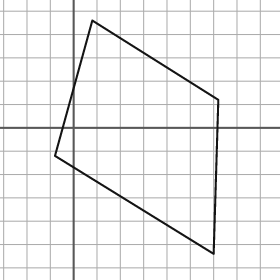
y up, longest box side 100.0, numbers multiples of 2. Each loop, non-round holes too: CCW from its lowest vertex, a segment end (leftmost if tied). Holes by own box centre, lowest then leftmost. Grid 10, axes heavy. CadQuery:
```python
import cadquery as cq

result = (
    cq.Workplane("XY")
    .moveTo(60.0, -54.0)
    .lineTo(62.0, 12.0)
    .lineTo(8.0, 46.0)
    .lineTo(-8.0, -12.0)
    .close()
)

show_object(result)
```